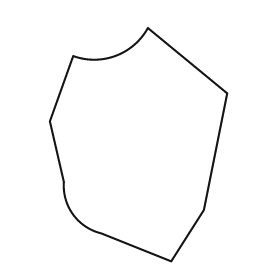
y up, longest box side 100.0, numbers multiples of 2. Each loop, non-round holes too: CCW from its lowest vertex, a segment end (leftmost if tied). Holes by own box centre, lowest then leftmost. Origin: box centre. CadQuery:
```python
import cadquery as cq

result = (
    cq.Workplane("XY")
    .moveTo(14.0, -50.0)
    .lineTo(28.0, -28.0)
    .lineTo(38.0, 22.0)
    .lineTo(4.0, 50.0)
    .threePointArc((-10.0, 38.0), (-28.0, 38.0))
    .lineTo(-38.0, 10.0)
    .lineTo(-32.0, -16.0)
    .threePointArc((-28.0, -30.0), (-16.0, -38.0))
    .close()
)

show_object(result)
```